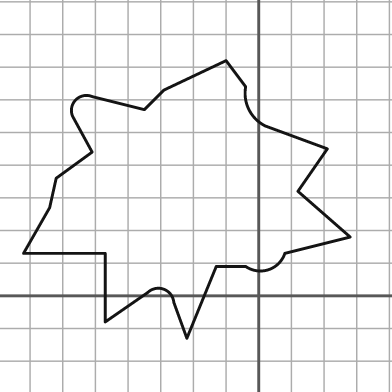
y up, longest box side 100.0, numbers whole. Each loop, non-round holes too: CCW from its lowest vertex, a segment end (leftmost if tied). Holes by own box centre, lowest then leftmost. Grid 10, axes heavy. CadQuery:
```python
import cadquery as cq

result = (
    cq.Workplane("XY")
    .moveTo(-22.0, -13.0)
    .lineTo(-13.0, 9.0)
    .lineTo(-4.0, 9.0)
    .threePointArc((3.0, 8.0), (8.0, 13.0))
    .lineTo(28.0, 18.0)
    .lineTo(12.0, 32.0)
    .lineTo(21.0, 45.0)
    .lineTo(2.0, 52.0)
    .threePointArc((-3.0, 57.0), (-4.0, 64.0))
    .lineTo(-10.0, 72.0)
    .lineTo(-29.0, 63.0)
    .lineTo(-35.0, 57.0)
    .lineTo(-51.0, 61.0)
    .threePointArc((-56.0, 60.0), (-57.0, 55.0))
    .lineTo(-51.0, 44.0)
    .lineTo(-62.0, 36.0)
    .lineTo(-64.0, 27.0)
    .lineTo(-72.0, 13.0)
    .lineTo(-47.0, 13.0)
    .lineTo(-47.0, -8.0)
    .lineTo(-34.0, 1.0)
    .threePointArc((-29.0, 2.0), (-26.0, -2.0))
    .close()
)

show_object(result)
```